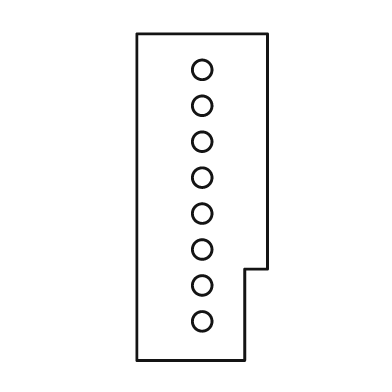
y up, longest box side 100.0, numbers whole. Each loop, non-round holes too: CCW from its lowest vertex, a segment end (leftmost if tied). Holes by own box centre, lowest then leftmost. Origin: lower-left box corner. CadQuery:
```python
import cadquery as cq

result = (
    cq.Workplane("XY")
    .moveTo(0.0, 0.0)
    .lineTo(33.0, 0.0)
    .lineTo(33.0, 28.0)
    .lineTo(40.0, 28.0)
    .lineTo(40.0, 100.0)
    .lineTo(0.0, 100.0)
    .close()
    .moveTo(20.0, 12.0)
    .circle(3.0)
    .moveTo(20.0, 23.0)
    .circle(3.0)
    .moveTo(20.0, 34.0)
    .circle(3.0)
    .moveTo(20.0, 45.0)
    .circle(3.0)
    .moveTo(20.0, 56.0)
    .circle(3.0)
    .moveTo(20.0, 67.0)
    .circle(3.0)
    .moveTo(20.0, 78.0)
    .circle(3.0)
    .moveTo(20.0, 89.0)
    .circle(3.0)
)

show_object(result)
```